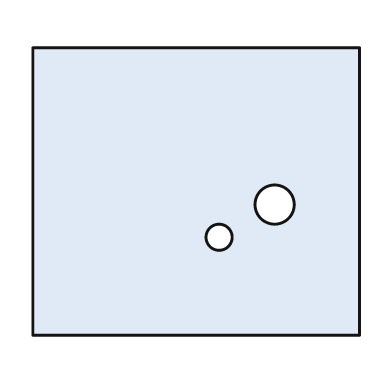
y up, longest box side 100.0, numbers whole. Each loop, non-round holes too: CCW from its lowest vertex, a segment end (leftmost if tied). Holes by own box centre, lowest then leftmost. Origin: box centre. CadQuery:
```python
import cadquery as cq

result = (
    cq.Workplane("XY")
    .moveTo(-50.0, -44.0)
    .lineTo(50.0, -44.0)
    .lineTo(50.0, 44.0)
    .lineTo(-50.0, 44.0)
    .close()
    .moveTo(7.0, -14.0)
    .circle(4.0)
    .moveTo(24.0, -4.0)
    .circle(6.0)
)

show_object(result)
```